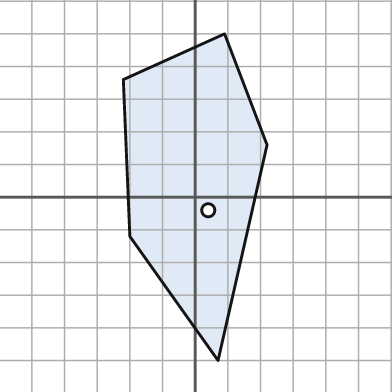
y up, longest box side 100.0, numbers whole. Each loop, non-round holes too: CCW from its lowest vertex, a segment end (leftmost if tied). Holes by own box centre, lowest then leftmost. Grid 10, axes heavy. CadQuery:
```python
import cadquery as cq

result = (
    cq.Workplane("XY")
    .moveTo(7.0, -50.0)
    .lineTo(22.0, 16.0)
    .lineTo(9.0, 50.0)
    .lineTo(-22.0, 36.0)
    .lineTo(-20.0, -12.0)
    .close()
    .moveTo(4.0, -4.0)
    .circle(2.0)
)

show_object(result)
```